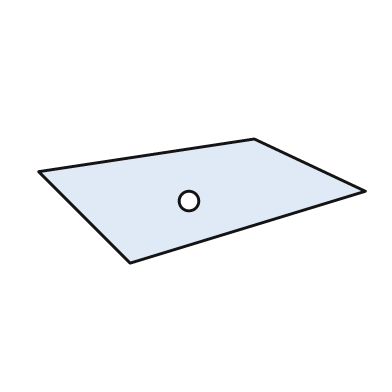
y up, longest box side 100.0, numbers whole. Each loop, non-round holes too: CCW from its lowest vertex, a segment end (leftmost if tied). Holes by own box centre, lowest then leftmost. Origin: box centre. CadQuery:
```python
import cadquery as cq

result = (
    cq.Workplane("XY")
    .moveTo(-22.0, -19.0)
    .lineTo(50.0, 3.0)
    .lineTo(16.0, 19.0)
    .lineTo(-50.0, 9.0)
    .close()
    .moveTo(-4.0, 0.0)
    .circle(3.0)
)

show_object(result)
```